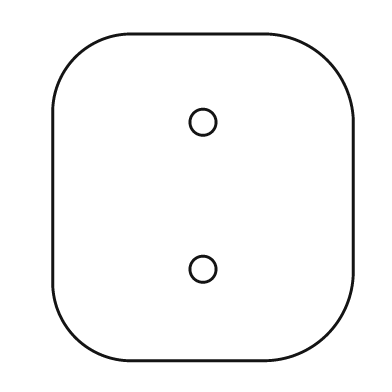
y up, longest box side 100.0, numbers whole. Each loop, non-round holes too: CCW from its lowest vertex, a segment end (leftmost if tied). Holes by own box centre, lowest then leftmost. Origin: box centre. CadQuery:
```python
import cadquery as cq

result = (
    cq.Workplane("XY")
    .moveTo(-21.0, -50.0)
    .lineTo(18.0, -50.0)
    .threePointArc((38.0, -42.0), (46.0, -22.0))
    .lineTo(46.0, 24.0)
    .threePointArc((38.0, 42.0), (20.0, 50.0))
    .lineTo(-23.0, 50.0)
    .threePointArc((-39.0, 43.0), (-46.0, 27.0))
    .lineTo(-46.0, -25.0)
    .threePointArc((-39.0, -43.0), (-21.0, -50.0))
    .close()
    .moveTo(0.0, -22.0)
    .circle(4.0)
    .moveTo(0.0, 23.0)
    .circle(4.0)
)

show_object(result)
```